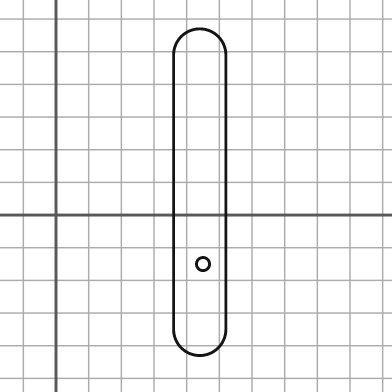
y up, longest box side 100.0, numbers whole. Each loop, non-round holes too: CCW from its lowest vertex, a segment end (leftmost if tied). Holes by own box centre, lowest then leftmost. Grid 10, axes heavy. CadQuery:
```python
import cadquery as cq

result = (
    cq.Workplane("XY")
    .moveTo(36.0, -35.0)
    .threePointArc((44.0, -43.0), (52.0, -35.0))
    .lineTo(52.0, 49.0)
    .threePointArc((44.0, 57.0), (36.0, 49.0))
    .close()
    .moveTo(45.0, -15.0)
    .circle(2.0)
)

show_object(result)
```